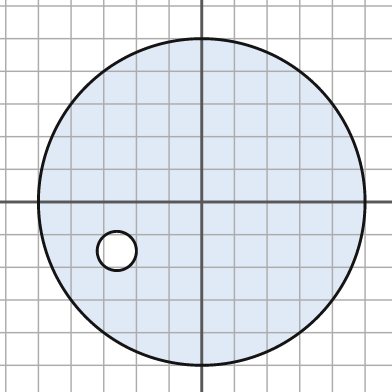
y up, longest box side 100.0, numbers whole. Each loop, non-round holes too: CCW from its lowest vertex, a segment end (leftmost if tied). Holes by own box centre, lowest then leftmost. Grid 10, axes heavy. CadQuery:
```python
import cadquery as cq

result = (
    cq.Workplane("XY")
    .moveTo(0.0, 0.0)
    .circle(50.0)
    .moveTo(-26.0, -15.0)
    .circle(6.0)
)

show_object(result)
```